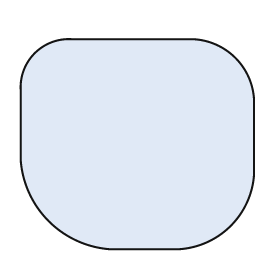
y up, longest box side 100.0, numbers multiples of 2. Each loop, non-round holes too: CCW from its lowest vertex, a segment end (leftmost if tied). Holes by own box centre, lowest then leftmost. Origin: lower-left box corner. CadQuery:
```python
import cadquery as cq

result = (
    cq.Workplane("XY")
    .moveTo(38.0, 0.0)
    .lineTo(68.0, 0.0)
    .threePointArc((90.0, 10.0), (100.0, 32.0))
    .lineTo(100.0, 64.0)
    .threePointArc((92.0, 82.0), (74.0, 90.0))
    .lineTo(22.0, 90.0)
    .threePointArc((6.0, 84.0), (0.0, 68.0))
    .lineTo(0.0, 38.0)
    .threePointArc((12.0, 12.0), (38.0, 0.0))
    .close()
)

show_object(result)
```